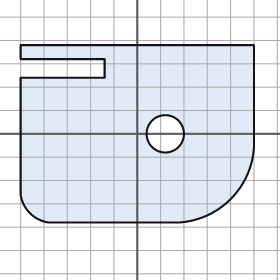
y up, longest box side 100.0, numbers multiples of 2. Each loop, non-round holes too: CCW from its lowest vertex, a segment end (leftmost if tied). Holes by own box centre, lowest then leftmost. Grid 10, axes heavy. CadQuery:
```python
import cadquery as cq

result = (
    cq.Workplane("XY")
    .moveTo(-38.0, -38.0)
    .lineTo(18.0, -38.0)
    .threePointArc((40.0, -28.0), (50.0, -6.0))
    .lineTo(50.0, 38.0)
    .lineTo(-50.0, 38.0)
    .lineTo(-50.0, 32.0)
    .lineTo(-14.0, 32.0)
    .lineTo(-14.0, 24.0)
    .lineTo(-50.0, 24.0)
    .lineTo(-50.0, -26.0)
    .threePointArc((-46.0, -34.0), (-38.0, -38.0))
    .close()
    .moveTo(12.0, 0.0)
    .circle(8.0)
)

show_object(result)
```